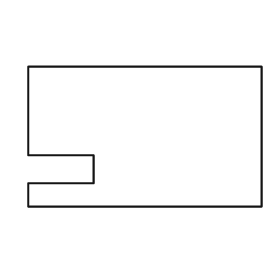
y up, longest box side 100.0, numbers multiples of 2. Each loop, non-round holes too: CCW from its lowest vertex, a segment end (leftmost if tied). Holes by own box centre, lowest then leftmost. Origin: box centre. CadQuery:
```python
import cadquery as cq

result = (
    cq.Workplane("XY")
    .moveTo(-50.0, -30.0)
    .lineTo(50.0, -30.0)
    .lineTo(50.0, 30.0)
    .lineTo(-50.0, 30.0)
    .lineTo(-50.0, -8.0)
    .lineTo(-22.0, -8.0)
    .lineTo(-22.0, -20.0)
    .lineTo(-50.0, -20.0)
    .close()
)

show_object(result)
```